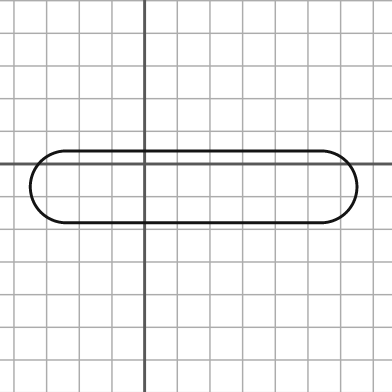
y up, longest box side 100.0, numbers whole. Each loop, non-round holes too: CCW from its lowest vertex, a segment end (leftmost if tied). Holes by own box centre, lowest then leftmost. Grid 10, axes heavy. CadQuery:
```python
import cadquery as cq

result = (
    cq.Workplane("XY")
    .moveTo(-24.0, -18.0)
    .lineTo(54.0, -18.0)
    .threePointArc((65.0, -7.0), (54.0, 4.0))
    .lineTo(-24.0, 4.0)
    .threePointArc((-35.0, -7.0), (-24.0, -18.0))
    .close()
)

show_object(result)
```